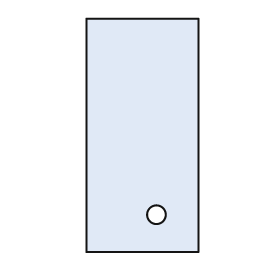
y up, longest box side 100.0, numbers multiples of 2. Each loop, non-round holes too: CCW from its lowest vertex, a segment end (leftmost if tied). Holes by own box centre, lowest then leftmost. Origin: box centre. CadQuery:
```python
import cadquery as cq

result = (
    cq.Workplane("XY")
    .moveTo(-24.0, -50.0)
    .lineTo(24.0, -50.0)
    .lineTo(24.0, 50.0)
    .lineTo(-24.0, 50.0)
    .close()
    .moveTo(6.0, -34.0)
    .circle(4.0)
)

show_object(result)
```